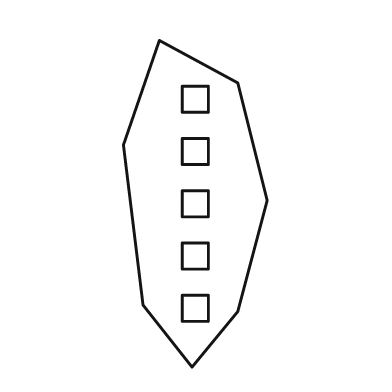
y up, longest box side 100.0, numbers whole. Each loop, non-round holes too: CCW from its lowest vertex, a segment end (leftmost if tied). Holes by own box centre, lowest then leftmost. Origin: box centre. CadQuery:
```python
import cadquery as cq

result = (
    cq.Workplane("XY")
    .moveTo(-1.0, -50.0)
    .lineTo(13.0, -33.0)
    .lineTo(22.0, 1.0)
    .lineTo(13.0, 37.0)
    .lineTo(-11.0, 50.0)
    .lineTo(-22.0, 18.0)
    .lineTo(-16.0, -31.0)
    .close()
    .moveTo(-4.0, -36.0)
    .lineTo(4.0, -36.0)
    .lineTo(4.0, -28.0)
    .lineTo(-4.0, -28.0)
    .close()
    .moveTo(-4.0, -20.0)
    .lineTo(4.0, -20.0)
    .lineTo(4.0, -12.0)
    .lineTo(-4.0, -12.0)
    .close()
    .moveTo(-4.0, -4.0)
    .lineTo(4.0, -4.0)
    .lineTo(4.0, 4.0)
    .lineTo(-4.0, 4.0)
    .close()
    .moveTo(-4.0, 12.0)
    .lineTo(4.0, 12.0)
    .lineTo(4.0, 20.0)
    .lineTo(-4.0, 20.0)
    .close()
    .moveTo(-4.0, 28.0)
    .lineTo(4.0, 28.0)
    .lineTo(4.0, 36.0)
    .lineTo(-4.0, 36.0)
    .close()
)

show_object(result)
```